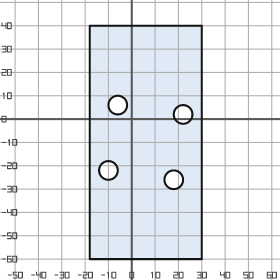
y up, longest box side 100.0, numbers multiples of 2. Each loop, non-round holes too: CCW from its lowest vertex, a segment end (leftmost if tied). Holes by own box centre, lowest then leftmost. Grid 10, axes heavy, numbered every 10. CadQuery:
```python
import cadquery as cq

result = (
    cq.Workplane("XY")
    .moveTo(-18.0, -60.0)
    .lineTo(30.0, -60.0)
    .lineTo(30.0, 40.0)
    .lineTo(-18.0, 40.0)
    .close()
    .moveTo(18.0, -26.0)
    .circle(4.0)
    .moveTo(-10.0, -22.0)
    .circle(4.0)
    .moveTo(22.0, 2.0)
    .circle(4.0)
    .moveTo(-6.0, 6.0)
    .circle(4.0)
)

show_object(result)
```